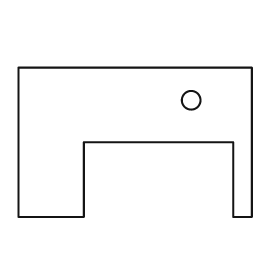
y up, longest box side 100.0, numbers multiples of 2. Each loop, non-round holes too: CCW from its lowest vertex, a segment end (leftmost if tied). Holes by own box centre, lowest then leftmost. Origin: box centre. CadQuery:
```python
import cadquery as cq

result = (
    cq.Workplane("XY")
    .moveTo(-50.0, -32.0)
    .lineTo(-22.0, -32.0)
    .lineTo(-22.0, 0.0)
    .lineTo(42.0, 0.0)
    .lineTo(42.0, -32.0)
    .lineTo(50.0, -32.0)
    .lineTo(50.0, 32.0)
    .lineTo(-50.0, 32.0)
    .close()
    .moveTo(24.0, 18.0)
    .circle(4.0)
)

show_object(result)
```